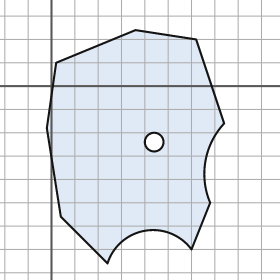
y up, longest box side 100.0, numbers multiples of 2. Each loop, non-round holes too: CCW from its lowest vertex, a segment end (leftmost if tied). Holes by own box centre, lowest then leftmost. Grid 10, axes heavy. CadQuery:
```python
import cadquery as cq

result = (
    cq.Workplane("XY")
    .moveTo(24.0, -76.0)
    .threePointArc((40.0, -62.0), (60.0, -70.0))
    .lineTo(68.0, -50.0)
    .threePointArc((66.0, -32.0), (74.0, -16.0))
    .lineTo(62.0, 20.0)
    .lineTo(36.0, 24.0)
    .lineTo(2.0, 10.0)
    .lineTo(-2.0, -18.0)
    .lineTo(4.0, -56.0)
    .close()
    .moveTo(44.0, -24.0)
    .circle(4.0)
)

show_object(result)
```